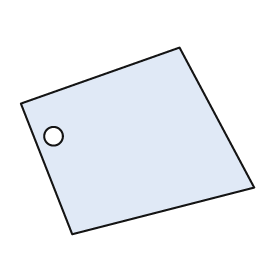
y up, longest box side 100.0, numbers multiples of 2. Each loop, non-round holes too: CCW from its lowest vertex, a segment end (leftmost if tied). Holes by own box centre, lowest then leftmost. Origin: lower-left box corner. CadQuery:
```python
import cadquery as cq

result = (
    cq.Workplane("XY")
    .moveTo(22.0, 0.0)
    .lineTo(100.0, 20.0)
    .lineTo(68.0, 80.0)
    .lineTo(0.0, 56.0)
    .close()
    .moveTo(14.0, 42.0)
    .circle(4.0)
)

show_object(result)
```